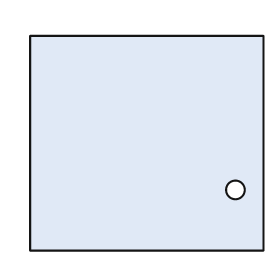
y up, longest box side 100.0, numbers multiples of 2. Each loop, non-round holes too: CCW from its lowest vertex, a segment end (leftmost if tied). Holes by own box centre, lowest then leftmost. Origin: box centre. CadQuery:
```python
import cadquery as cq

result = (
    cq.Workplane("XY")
    .moveTo(-50.0, -46.0)
    .lineTo(50.0, -46.0)
    .lineTo(50.0, 46.0)
    .lineTo(-50.0, 46.0)
    .close()
    .moveTo(38.0, -20.0)
    .circle(4.0)
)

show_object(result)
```